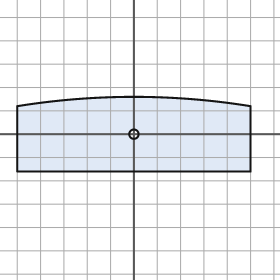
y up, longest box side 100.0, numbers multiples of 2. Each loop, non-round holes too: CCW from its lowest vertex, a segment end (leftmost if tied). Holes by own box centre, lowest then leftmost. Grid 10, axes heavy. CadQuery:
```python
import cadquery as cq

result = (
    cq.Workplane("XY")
    .moveTo(-50.0, -16.0)
    .lineTo(50.0, -16.0)
    .lineTo(50.0, 12.0)
    .threePointArc((0.0, 16.0), (-50.0, 12.0))
    .close()
    .moveTo(0.0, 0.0)
    .circle(2.0)
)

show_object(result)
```